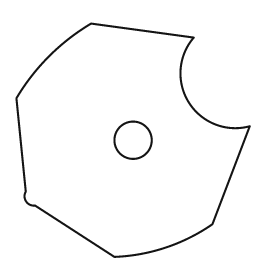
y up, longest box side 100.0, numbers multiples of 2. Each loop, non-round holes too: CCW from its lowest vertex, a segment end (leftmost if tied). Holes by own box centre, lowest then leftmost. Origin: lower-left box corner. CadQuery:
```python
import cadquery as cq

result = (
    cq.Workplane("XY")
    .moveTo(42.0, 0.0)
    .threePointArc((64.0, 4.0), (84.0, 14.0))
    .lineTo(100.0, 56.0)
    .threePointArc((74.0, 66.0), (76.0, 94.0))
    .lineTo(32.0, 100.0)
    .threePointArc((14.0, 86.0), (0.0, 68.0))
    .lineTo(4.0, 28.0)
    .threePointArc((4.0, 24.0), (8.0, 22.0))
    .close()
    .moveTo(50.0, 50.0)
    .circle(8.0)
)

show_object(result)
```